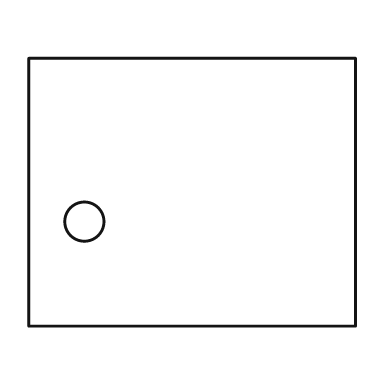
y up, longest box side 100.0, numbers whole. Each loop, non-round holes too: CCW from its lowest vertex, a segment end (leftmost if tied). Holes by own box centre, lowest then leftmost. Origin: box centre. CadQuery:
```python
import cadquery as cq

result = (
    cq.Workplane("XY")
    .moveTo(-50.0, -41.0)
    .lineTo(50.0, -41.0)
    .lineTo(50.0, 41.0)
    .lineTo(-50.0, 41.0)
    .close()
    .moveTo(-33.0, -9.0)
    .circle(6.0)
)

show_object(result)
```